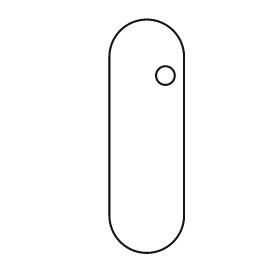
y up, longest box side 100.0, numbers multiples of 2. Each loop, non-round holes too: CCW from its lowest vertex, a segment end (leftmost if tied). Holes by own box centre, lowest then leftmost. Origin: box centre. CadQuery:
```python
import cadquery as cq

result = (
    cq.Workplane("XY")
    .moveTo(-16.0, -34.0)
    .threePointArc((0.0, -50.0), (16.0, -34.0))
    .lineTo(16.0, 34.0)
    .threePointArc((0.0, 50.0), (-16.0, 34.0))
    .close()
    .moveTo(8.0, 26.0)
    .circle(4.0)
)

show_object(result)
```